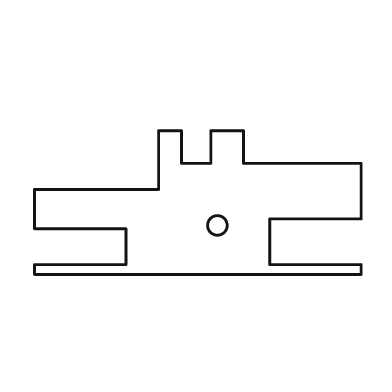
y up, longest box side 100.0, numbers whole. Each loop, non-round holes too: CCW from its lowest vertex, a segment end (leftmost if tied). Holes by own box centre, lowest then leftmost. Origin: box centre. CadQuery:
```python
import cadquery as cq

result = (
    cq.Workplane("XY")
    .moveTo(-50.0, -22.0)
    .lineTo(50.0, -22.0)
    .lineTo(50.0, -19.0)
    .lineTo(22.0, -19.0)
    .lineTo(22.0, -5.0)
    .lineTo(50.0, -5.0)
    .lineTo(50.0, 12.0)
    .lineTo(14.0, 12.0)
    .lineTo(14.0, 22.0)
    .lineTo(4.0, 22.0)
    .lineTo(4.0, 12.0)
    .lineTo(-5.0, 12.0)
    .lineTo(-5.0, 22.0)
    .lineTo(-12.0, 22.0)
    .lineTo(-12.0, 4.0)
    .lineTo(-50.0, 4.0)
    .lineTo(-50.0, -8.0)
    .lineTo(-22.0, -8.0)
    .lineTo(-22.0, -19.0)
    .lineTo(-50.0, -19.0)
    .close()
    .moveTo(6.0, -7.0)
    .circle(3.0)
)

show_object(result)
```